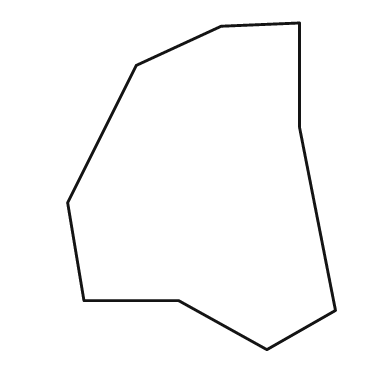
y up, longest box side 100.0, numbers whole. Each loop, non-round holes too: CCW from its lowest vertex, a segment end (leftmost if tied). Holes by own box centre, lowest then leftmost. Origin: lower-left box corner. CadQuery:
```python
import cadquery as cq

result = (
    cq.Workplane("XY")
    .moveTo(61.0, 0.0)
    .lineTo(82.0, 12.0)
    .lineTo(71.0, 68.0)
    .lineTo(71.0, 100.0)
    .lineTo(47.0, 99.0)
    .lineTo(21.0, 87.0)
    .lineTo(0.0, 45.0)
    .lineTo(5.0, 15.0)
    .lineTo(34.0, 15.0)
    .close()
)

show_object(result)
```